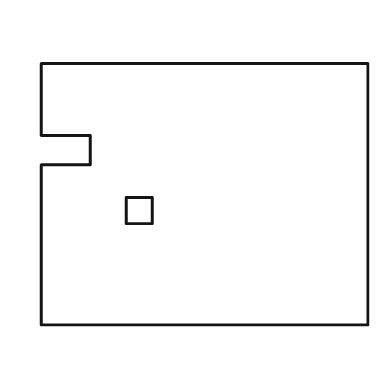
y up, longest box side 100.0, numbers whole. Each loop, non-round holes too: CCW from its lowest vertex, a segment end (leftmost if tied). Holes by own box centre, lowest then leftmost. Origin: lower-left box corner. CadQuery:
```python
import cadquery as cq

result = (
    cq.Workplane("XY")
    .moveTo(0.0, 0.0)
    .lineTo(100.0, 0.0)
    .lineTo(100.0, 80.0)
    .lineTo(0.0, 80.0)
    .lineTo(0.0, 58.0)
    .lineTo(15.0, 58.0)
    .lineTo(15.0, 49.0)
    .lineTo(0.0, 49.0)
    .close()
    .moveTo(26.0, 31.0)
    .lineTo(34.0, 31.0)
    .lineTo(34.0, 39.0)
    .lineTo(26.0, 39.0)
    .close()
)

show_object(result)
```